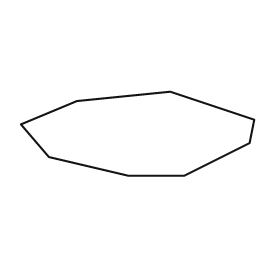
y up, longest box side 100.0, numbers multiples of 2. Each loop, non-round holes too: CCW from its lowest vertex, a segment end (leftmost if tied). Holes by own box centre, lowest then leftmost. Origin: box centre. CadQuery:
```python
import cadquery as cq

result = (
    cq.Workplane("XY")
    .moveTo(-4.0, -18.0)
    .lineTo(20.0, -18.0)
    .lineTo(48.0, -4.0)
    .lineTo(50.0, 6.0)
    .lineTo(14.0, 18.0)
    .lineTo(-26.0, 14.0)
    .lineTo(-50.0, 4.0)
    .lineTo(-38.0, -10.0)
    .close()
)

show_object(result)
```